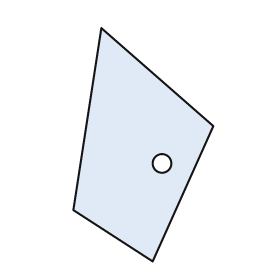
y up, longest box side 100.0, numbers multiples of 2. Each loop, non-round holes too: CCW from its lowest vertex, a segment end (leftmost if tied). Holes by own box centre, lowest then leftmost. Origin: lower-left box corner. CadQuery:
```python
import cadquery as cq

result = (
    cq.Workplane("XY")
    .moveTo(34.0, 0.0)
    .lineTo(60.0, 58.0)
    .lineTo(12.0, 100.0)
    .lineTo(0.0, 22.0)
    .close()
    .moveTo(38.0, 42.0)
    .circle(4.0)
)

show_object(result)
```